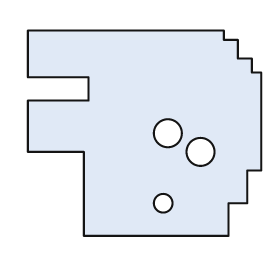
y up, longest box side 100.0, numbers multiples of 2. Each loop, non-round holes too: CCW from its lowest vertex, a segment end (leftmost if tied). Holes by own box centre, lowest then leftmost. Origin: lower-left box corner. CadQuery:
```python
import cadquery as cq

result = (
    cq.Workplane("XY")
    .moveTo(24.0, 0.0)
    .lineTo(86.0, 0.0)
    .lineTo(86.0, 14.0)
    .lineTo(94.0, 14.0)
    .lineTo(94.0, 28.0)
    .lineTo(100.0, 28.0)
    .lineTo(100.0, 70.0)
    .lineTo(96.0, 70.0)
    .lineTo(96.0, 76.0)
    .lineTo(90.0, 76.0)
    .lineTo(90.0, 84.0)
    .lineTo(84.0, 84.0)
    .lineTo(84.0, 88.0)
    .lineTo(0.0, 88.0)
    .lineTo(0.0, 68.0)
    .lineTo(26.0, 68.0)
    .lineTo(26.0, 58.0)
    .lineTo(0.0, 58.0)
    .lineTo(0.0, 36.0)
    .lineTo(24.0, 36.0)
    .close()
    .moveTo(58.0, 14.0)
    .circle(4.0)
    .moveTo(74.0, 36.0)
    .circle(6.0)
    .moveTo(60.0, 44.0)
    .circle(6.0)
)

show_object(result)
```